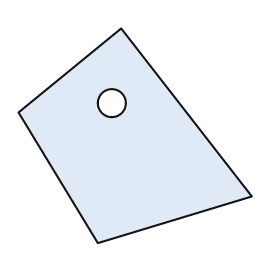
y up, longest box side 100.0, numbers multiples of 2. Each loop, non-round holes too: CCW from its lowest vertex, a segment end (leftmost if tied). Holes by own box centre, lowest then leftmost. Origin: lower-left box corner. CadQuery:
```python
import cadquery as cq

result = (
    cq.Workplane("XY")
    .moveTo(34.0, 0.0)
    .lineTo(100.0, 20.0)
    .lineTo(44.0, 92.0)
    .lineTo(0.0, 56.0)
    .close()
    .moveTo(40.0, 60.0)
    .circle(6.0)
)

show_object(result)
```